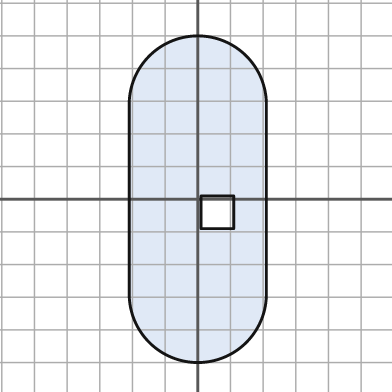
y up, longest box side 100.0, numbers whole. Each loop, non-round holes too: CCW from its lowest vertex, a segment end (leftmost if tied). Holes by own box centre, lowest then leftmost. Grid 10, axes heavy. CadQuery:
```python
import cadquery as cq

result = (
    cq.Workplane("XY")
    .moveTo(-21.0, -29.0)
    .threePointArc((0.0, -50.0), (21.0, -29.0))
    .lineTo(21.0, 29.0)
    .threePointArc((0.0, 50.0), (-21.0, 29.0))
    .close()
    .moveTo(1.0, -9.0)
    .lineTo(11.0, -9.0)
    .lineTo(11.0, 1.0)
    .lineTo(1.0, 1.0)
    .close()
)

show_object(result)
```